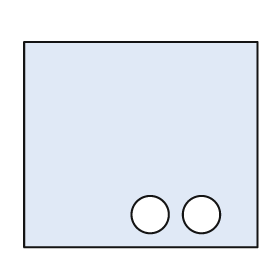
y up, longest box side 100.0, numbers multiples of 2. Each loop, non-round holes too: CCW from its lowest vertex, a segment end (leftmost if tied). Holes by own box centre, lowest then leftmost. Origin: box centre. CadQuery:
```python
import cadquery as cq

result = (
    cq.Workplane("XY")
    .moveTo(-50.0, -44.0)
    .lineTo(50.0, -44.0)
    .lineTo(50.0, 44.0)
    .lineTo(-50.0, 44.0)
    .close()
    .moveTo(4.0, -30.0)
    .circle(8.0)
    .moveTo(26.0, -30.0)
    .circle(8.0)
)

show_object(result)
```